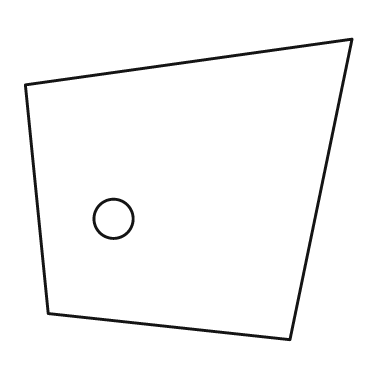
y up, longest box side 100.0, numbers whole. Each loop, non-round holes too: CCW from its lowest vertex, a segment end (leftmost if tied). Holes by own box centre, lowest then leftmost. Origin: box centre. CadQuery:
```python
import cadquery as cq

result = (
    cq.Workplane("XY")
    .moveTo(31.0, -46.0)
    .lineTo(50.0, 46.0)
    .lineTo(-50.0, 32.0)
    .lineTo(-43.0, -38.0)
    .close()
    .moveTo(-23.0, -9.0)
    .circle(6.0)
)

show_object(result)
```